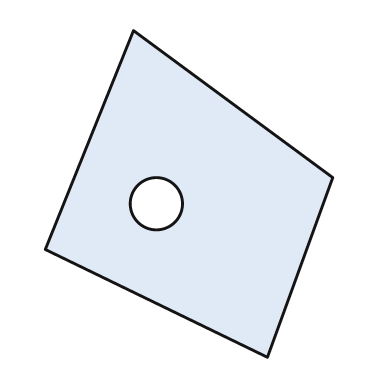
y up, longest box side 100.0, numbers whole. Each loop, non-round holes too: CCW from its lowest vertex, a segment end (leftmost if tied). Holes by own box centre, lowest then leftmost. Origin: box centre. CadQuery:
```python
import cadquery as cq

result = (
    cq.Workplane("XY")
    .moveTo(24.0, -50.0)
    .lineTo(44.0, 5.0)
    .lineTo(-17.0, 50.0)
    .lineTo(-44.0, -17.0)
    .close()
    .moveTo(-10.0, -3.0)
    .circle(8.0)
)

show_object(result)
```